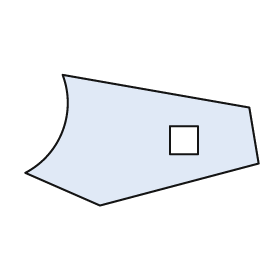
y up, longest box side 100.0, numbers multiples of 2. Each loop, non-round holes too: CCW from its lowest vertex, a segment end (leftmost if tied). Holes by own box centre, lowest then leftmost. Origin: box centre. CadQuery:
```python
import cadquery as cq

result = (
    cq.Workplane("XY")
    .moveTo(-18.0, -28.0)
    .lineTo(50.0, -10.0)
    .lineTo(46.0, 14.0)
    .lineTo(-34.0, 28.0)
    .threePointArc((-34.0, 4.0), (-50.0, -14.0))
    .close()
    .moveTo(12.0, -6.0)
    .lineTo(24.0, -6.0)
    .lineTo(24.0, 6.0)
    .lineTo(12.0, 6.0)
    .close()
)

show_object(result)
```